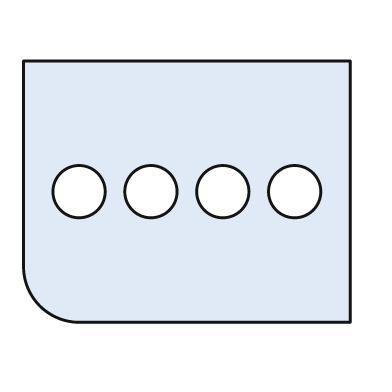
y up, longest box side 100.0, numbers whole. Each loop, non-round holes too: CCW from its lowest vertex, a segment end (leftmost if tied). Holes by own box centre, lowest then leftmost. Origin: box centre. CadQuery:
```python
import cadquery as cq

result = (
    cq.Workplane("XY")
    .moveTo(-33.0, -40.0)
    .lineTo(50.0, -40.0)
    .lineTo(50.0, 40.0)
    .lineTo(-50.0, 40.0)
    .lineTo(-50.0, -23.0)
    .threePointArc((-45.0, -35.0), (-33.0, -40.0))
    .close()
    .moveTo(-33.0, 0.0)
    .circle(8.0)
    .moveTo(-11.0, 0.0)
    .circle(8.0)
    .moveTo(11.0, 0.0)
    .circle(8.0)
    .moveTo(33.0, 0.0)
    .circle(8.0)
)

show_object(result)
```